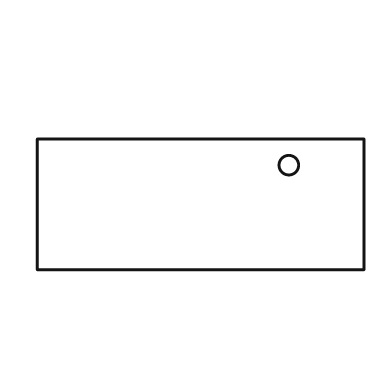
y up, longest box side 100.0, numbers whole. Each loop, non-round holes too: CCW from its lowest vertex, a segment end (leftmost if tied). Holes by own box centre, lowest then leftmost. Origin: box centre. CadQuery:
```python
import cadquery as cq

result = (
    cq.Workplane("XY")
    .moveTo(-50.0, -20.0)
    .lineTo(50.0, -20.0)
    .lineTo(50.0, 20.0)
    .lineTo(-50.0, 20.0)
    .close()
    .moveTo(27.0, 12.0)
    .circle(3.0)
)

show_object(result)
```